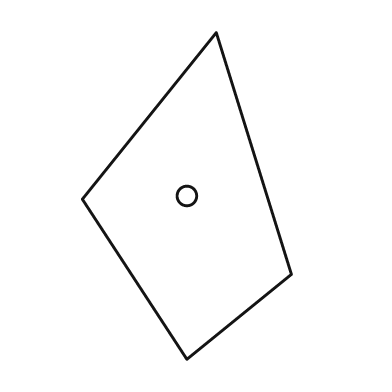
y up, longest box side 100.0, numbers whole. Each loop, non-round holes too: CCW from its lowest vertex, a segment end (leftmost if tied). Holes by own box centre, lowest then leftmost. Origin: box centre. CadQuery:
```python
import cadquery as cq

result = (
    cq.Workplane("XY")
    .moveTo(0.0, -50.0)
    .lineTo(32.0, -24.0)
    .lineTo(9.0, 50.0)
    .lineTo(-32.0, -1.0)
    .close()
    .moveTo(0.0, 0.0)
    .circle(3.0)
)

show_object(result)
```